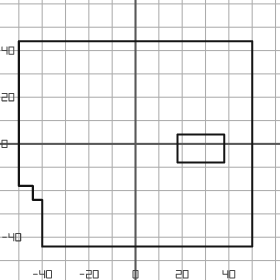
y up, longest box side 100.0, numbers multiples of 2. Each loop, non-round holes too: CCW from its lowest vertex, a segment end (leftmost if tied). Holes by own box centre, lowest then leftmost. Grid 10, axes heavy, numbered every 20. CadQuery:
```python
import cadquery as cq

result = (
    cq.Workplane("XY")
    .moveTo(-40.0, -44.0)
    .lineTo(50.0, -44.0)
    .lineTo(50.0, 44.0)
    .lineTo(-50.0, 44.0)
    .lineTo(-50.0, -18.0)
    .lineTo(-44.0, -18.0)
    .lineTo(-44.0, -24.0)
    .lineTo(-40.0, -24.0)
    .close()
    .moveTo(18.0, -8.0)
    .lineTo(38.0, -8.0)
    .lineTo(38.0, 4.0)
    .lineTo(18.0, 4.0)
    .close()
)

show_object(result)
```